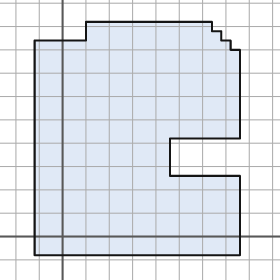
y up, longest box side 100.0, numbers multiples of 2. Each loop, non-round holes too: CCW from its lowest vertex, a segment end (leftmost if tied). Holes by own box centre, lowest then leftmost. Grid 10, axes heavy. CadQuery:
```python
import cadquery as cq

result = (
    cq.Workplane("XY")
    .moveTo(-12.0, -8.0)
    .lineTo(76.0, -8.0)
    .lineTo(76.0, 26.0)
    .lineTo(46.0, 26.0)
    .lineTo(46.0, 42.0)
    .lineTo(76.0, 42.0)
    .lineTo(76.0, 80.0)
    .lineTo(72.0, 80.0)
    .lineTo(72.0, 84.0)
    .lineTo(68.0, 84.0)
    .lineTo(68.0, 88.0)
    .lineTo(64.0, 88.0)
    .lineTo(64.0, 92.0)
    .lineTo(10.0, 92.0)
    .lineTo(10.0, 84.0)
    .lineTo(-12.0, 84.0)
    .close()
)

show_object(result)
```